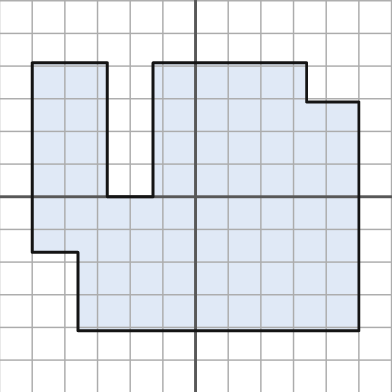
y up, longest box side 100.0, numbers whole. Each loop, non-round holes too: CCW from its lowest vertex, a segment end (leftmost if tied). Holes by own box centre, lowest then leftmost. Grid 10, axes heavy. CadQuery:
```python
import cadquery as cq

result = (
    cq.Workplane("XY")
    .moveTo(-36.0, -41.0)
    .lineTo(50.0, -41.0)
    .lineTo(50.0, 29.0)
    .lineTo(34.0, 29.0)
    .lineTo(34.0, 41.0)
    .lineTo(-13.0, 41.0)
    .lineTo(-13.0, 0.0)
    .lineTo(-27.0, 0.0)
    .lineTo(-27.0, 41.0)
    .lineTo(-50.0, 41.0)
    .lineTo(-50.0, -17.0)
    .lineTo(-36.0, -17.0)
    .close()
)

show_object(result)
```